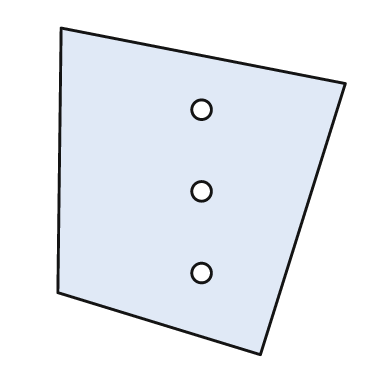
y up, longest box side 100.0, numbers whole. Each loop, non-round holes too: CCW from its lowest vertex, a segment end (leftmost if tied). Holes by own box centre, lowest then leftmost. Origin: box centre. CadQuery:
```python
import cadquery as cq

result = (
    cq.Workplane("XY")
    .moveTo(18.0, -50.0)
    .lineTo(44.0, 33.0)
    .lineTo(-43.0, 50.0)
    .lineTo(-44.0, -31.0)
    .close()
    .moveTo(0.0, -25.0)
    .circle(3.0)
    .moveTo(0.0, 0.0)
    .circle(3.0)
    .moveTo(0.0, 25.0)
    .circle(3.0)
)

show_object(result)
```